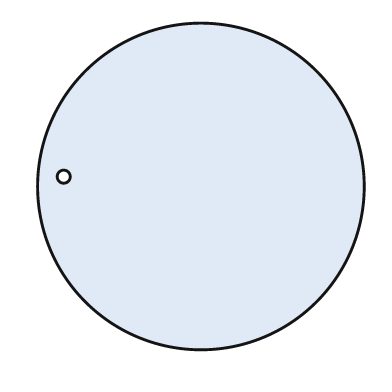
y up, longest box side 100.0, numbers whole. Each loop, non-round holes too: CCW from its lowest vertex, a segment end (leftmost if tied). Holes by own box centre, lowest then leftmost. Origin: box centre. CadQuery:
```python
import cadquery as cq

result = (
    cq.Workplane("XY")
    .moveTo(0.0, 0.0)
    .circle(50.0)
    .moveTo(-42.0, 3.0)
    .circle(2.0)
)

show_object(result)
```